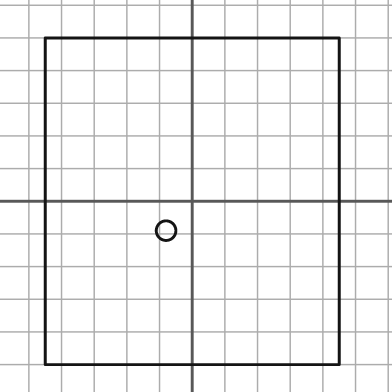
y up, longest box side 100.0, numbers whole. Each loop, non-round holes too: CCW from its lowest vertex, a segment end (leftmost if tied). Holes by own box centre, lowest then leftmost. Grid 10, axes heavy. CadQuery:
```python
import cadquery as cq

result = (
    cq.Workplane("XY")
    .moveTo(-45.0, -50.0)
    .lineTo(45.0, -50.0)
    .lineTo(45.0, 50.0)
    .lineTo(-45.0, 50.0)
    .close()
    .moveTo(-8.0, -9.0)
    .circle(3.0)
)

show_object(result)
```